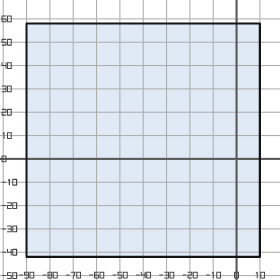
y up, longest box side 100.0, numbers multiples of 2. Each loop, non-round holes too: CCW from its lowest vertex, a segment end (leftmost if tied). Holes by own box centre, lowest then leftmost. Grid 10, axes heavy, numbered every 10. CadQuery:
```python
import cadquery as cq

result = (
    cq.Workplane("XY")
    .moveTo(-90.0, -42.0)
    .lineTo(10.0, -42.0)
    .lineTo(10.0, 58.0)
    .lineTo(-90.0, 58.0)
    .close()
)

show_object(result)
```